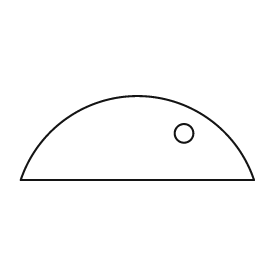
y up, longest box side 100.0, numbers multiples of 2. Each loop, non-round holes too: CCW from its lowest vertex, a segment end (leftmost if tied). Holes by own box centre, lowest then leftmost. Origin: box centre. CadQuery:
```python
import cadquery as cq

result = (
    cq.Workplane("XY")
    .moveTo(-50.0, -18.0)
    .lineTo(50.0, -18.0)
    .threePointArc((0.0, 18.0), (-50.0, -18.0))
    .close()
    .moveTo(20.0, 2.0)
    .circle(4.0)
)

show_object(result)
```